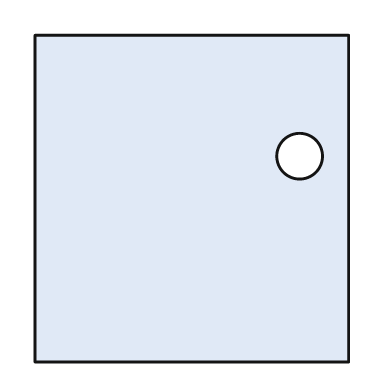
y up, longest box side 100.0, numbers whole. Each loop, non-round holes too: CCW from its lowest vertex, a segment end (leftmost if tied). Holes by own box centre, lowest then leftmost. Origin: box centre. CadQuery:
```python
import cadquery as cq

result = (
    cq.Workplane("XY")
    .moveTo(-48.0, -50.0)
    .lineTo(48.0, -50.0)
    .lineTo(48.0, 50.0)
    .lineTo(-48.0, 50.0)
    .close()
    .moveTo(33.0, 13.0)
    .circle(7.0)
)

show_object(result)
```